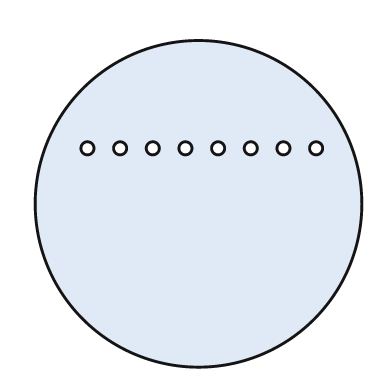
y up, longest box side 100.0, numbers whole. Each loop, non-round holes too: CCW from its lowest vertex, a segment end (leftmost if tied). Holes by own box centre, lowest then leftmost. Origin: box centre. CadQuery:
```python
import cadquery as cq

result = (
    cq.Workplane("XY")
    .moveTo(0.0, 0.0)
    .circle(50.0)
    .moveTo(-34.0, 17.0)
    .circle(2.0)
    .moveTo(-24.0, 17.0)
    .circle(2.0)
    .moveTo(-14.0, 17.0)
    .circle(2.0)
    .moveTo(-4.0, 17.0)
    .circle(2.0)
    .moveTo(6.0, 17.0)
    .circle(2.0)
    .moveTo(16.0, 17.0)
    .circle(2.0)
    .moveTo(26.0, 17.0)
    .circle(2.0)
    .moveTo(36.0, 17.0)
    .circle(2.0)
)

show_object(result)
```